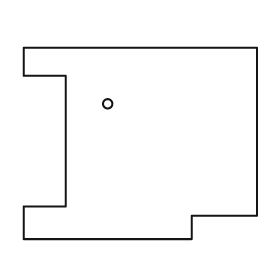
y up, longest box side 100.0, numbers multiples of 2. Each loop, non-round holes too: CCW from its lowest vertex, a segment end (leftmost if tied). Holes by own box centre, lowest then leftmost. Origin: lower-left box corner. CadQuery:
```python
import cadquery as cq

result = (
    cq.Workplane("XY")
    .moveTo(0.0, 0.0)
    .lineTo(72.0, 0.0)
    .lineTo(72.0, 10.0)
    .lineTo(100.0, 10.0)
    .lineTo(100.0, 82.0)
    .lineTo(0.0, 82.0)
    .lineTo(0.0, 70.0)
    .lineTo(18.0, 70.0)
    .lineTo(18.0, 14.0)
    .lineTo(0.0, 14.0)
    .close()
    .moveTo(36.0, 58.0)
    .circle(2.0)
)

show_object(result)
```